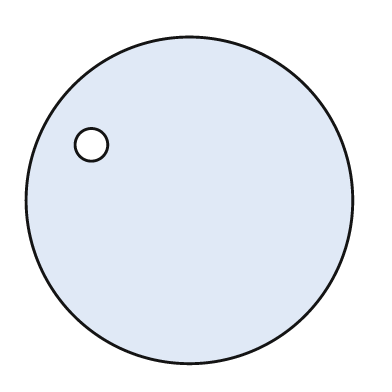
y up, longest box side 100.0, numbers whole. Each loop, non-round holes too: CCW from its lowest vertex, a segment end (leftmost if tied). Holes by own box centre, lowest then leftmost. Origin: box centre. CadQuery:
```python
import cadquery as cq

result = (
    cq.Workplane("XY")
    .moveTo(0.0, 0.0)
    .circle(50.0)
    .moveTo(-30.0, 17.0)
    .circle(5.0)
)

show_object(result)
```